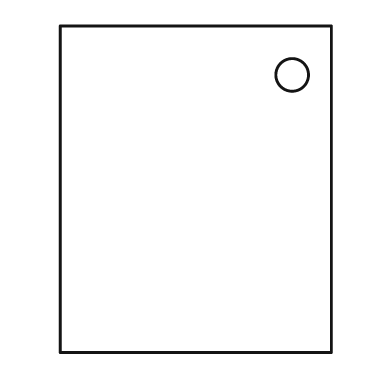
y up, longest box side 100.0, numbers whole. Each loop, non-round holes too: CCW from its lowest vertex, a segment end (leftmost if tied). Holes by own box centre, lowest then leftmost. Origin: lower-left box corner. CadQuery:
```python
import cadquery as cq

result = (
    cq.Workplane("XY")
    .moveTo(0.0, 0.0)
    .lineTo(83.0, 0.0)
    .lineTo(83.0, 100.0)
    .lineTo(0.0, 100.0)
    .close()
    .moveTo(71.0, 85.0)
    .circle(5.0)
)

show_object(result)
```